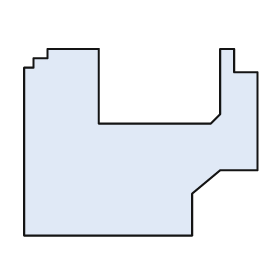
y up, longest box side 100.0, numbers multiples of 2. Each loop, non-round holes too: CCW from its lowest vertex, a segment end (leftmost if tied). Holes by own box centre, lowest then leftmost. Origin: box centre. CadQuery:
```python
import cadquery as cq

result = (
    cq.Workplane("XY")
    .moveTo(-50.0, -40.0)
    .lineTo(22.0, -40.0)
    .lineTo(22.0, -22.0)
    .lineTo(34.0, -12.0)
    .lineTo(50.0, -12.0)
    .lineTo(50.0, 30.0)
    .lineTo(40.0, 30.0)
    .lineTo(40.0, 40.0)
    .lineTo(34.0, 40.0)
    .lineTo(34.0, 12.0)
    .lineTo(30.0, 8.0)
    .lineTo(-18.0, 8.0)
    .lineTo(-18.0, 40.0)
    .lineTo(-40.0, 40.0)
    .lineTo(-40.0, 36.0)
    .lineTo(-46.0, 36.0)
    .lineTo(-46.0, 32.0)
    .lineTo(-50.0, 32.0)
    .close()
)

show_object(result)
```